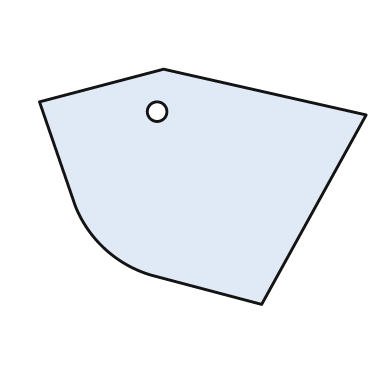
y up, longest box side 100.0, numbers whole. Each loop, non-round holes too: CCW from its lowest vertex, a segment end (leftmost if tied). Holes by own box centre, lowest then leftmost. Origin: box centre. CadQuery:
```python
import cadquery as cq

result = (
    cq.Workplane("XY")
    .moveTo(18.0, -36.0)
    .lineTo(50.0, 22.0)
    .lineTo(-12.0, 36.0)
    .lineTo(-50.0, 26.0)
    .lineTo(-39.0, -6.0)
    .threePointArc((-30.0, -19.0), (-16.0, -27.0))
    .close()
    .moveTo(-14.0, 23.0)
    .circle(3.0)
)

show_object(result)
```